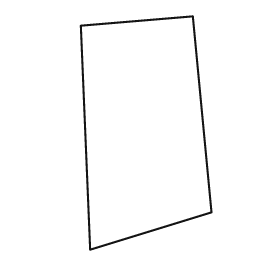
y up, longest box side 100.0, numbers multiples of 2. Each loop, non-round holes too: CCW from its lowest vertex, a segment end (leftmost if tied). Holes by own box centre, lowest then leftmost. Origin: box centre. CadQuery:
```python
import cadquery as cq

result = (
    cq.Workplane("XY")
    .moveTo(-24.0, -50.0)
    .lineTo(28.0, -34.0)
    .lineTo(20.0, 50.0)
    .lineTo(-28.0, 46.0)
    .close()
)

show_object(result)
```